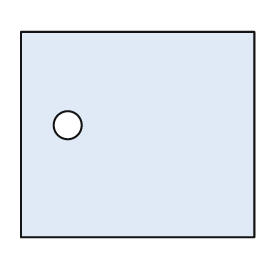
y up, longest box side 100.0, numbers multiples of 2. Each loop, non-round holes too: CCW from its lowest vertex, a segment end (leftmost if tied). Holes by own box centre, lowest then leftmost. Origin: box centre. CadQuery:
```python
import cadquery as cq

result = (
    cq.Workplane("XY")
    .moveTo(-50.0, -44.0)
    .lineTo(50.0, -44.0)
    .lineTo(50.0, 44.0)
    .lineTo(-50.0, 44.0)
    .close()
    .moveTo(-30.0, 4.0)
    .circle(6.0)
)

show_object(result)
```